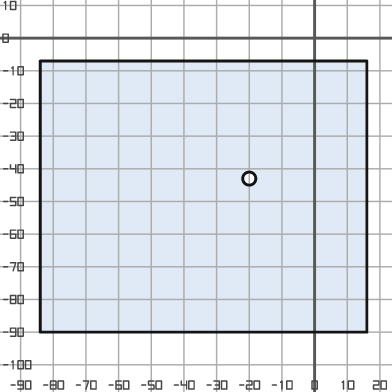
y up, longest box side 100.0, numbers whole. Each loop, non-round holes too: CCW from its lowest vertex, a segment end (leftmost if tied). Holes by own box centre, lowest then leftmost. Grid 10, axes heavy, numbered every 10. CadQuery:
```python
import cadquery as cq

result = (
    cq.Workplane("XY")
    .moveTo(-84.0, -90.0)
    .lineTo(16.0, -90.0)
    .lineTo(16.0, -7.0)
    .lineTo(-84.0, -7.0)
    .close()
    .moveTo(-20.0, -43.0)
    .circle(2.0)
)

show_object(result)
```